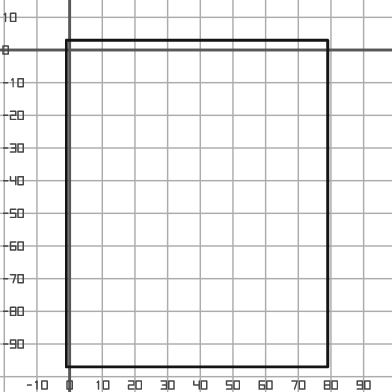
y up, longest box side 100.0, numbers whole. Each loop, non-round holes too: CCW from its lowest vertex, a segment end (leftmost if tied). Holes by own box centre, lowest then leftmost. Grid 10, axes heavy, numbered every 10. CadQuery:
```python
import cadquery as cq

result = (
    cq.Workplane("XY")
    .moveTo(-1.0, -97.0)
    .lineTo(79.0, -97.0)
    .lineTo(79.0, 3.0)
    .lineTo(-1.0, 3.0)
    .close()
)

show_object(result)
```